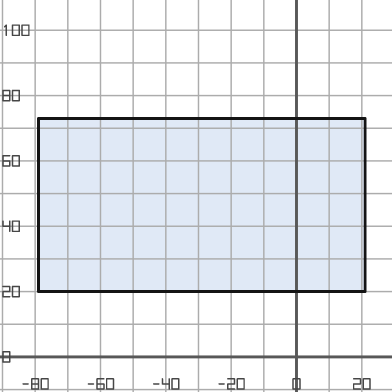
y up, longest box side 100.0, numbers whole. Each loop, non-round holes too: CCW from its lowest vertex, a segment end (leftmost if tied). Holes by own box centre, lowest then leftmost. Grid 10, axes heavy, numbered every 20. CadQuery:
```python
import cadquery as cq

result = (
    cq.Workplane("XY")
    .moveTo(-79.0, 20.0)
    .lineTo(21.0, 20.0)
    .lineTo(21.0, 73.0)
    .lineTo(-79.0, 73.0)
    .close()
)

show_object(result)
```